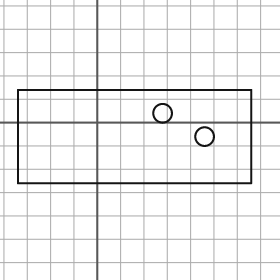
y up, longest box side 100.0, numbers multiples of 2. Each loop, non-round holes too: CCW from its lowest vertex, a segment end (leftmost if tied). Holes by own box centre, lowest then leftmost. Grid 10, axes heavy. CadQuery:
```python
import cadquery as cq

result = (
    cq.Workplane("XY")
    .moveTo(-34.0, -26.0)
    .lineTo(66.0, -26.0)
    .lineTo(66.0, 14.0)
    .lineTo(-34.0, 14.0)
    .close()
    .moveTo(46.0, -6.0)
    .circle(4.0)
    .moveTo(28.0, 4.0)
    .circle(4.0)
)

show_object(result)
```